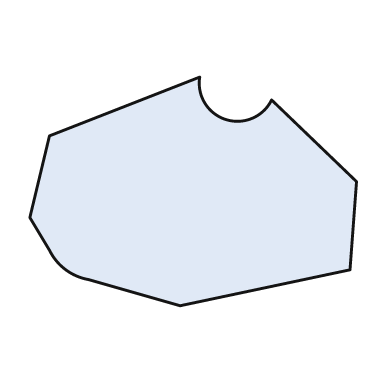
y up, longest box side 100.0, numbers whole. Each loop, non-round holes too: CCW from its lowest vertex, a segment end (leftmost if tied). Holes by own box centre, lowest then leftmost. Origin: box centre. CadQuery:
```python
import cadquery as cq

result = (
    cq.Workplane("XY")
    .moveTo(-4.0, -35.0)
    .lineTo(48.0, -24.0)
    .lineTo(50.0, 3.0)
    .lineTo(24.0, 28.0)
    .threePointArc((10.0, 22.0), (2.0, 35.0))
    .lineTo(-44.0, 17.0)
    .lineTo(-50.0, -8.0)
    .lineTo(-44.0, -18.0)
    .threePointArc((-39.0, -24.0), (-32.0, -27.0))
    .close()
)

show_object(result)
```